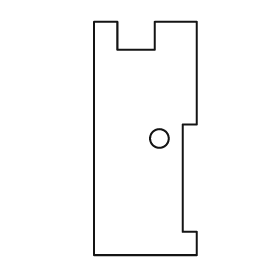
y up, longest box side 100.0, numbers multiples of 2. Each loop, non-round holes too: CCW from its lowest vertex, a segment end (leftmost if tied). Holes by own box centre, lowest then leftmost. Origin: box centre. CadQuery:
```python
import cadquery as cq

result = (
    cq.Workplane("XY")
    .moveTo(-22.0, -50.0)
    .lineTo(22.0, -50.0)
    .lineTo(22.0, -40.0)
    .lineTo(16.0, -40.0)
    .lineTo(16.0, 6.0)
    .lineTo(22.0, 6.0)
    .lineTo(22.0, 50.0)
    .lineTo(4.0, 50.0)
    .lineTo(4.0, 38.0)
    .lineTo(-12.0, 38.0)
    .lineTo(-12.0, 50.0)
    .lineTo(-22.0, 50.0)
    .close()
    .moveTo(6.0, 0.0)
    .circle(4.0)
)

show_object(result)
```